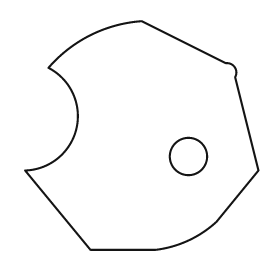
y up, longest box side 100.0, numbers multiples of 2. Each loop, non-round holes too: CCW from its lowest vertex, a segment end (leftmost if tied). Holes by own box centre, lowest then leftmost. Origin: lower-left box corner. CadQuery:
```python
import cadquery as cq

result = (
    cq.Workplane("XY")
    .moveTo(28.0, 0.0)
    .lineTo(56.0, 0.0)
    .threePointArc((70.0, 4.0), (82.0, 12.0))
    .lineTo(100.0, 34.0)
    .lineTo(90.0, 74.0)
    .threePointArc((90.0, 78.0), (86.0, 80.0))
    .lineTo(50.0, 98.0)
    .threePointArc((28.0, 92.0), (10.0, 78.0))
    .threePointArc((22.0, 52.0), (0.0, 34.0))
    .close()
    .moveTo(70.0, 40.0)
    .circle(8.0)
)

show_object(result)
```